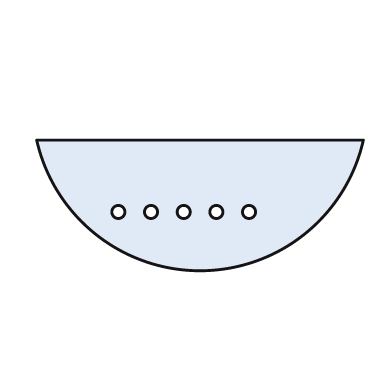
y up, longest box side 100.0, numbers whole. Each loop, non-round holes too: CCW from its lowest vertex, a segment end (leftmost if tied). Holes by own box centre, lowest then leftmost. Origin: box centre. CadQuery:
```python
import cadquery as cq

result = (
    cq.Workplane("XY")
    .moveTo(-50.0, 20.0)
    .threePointArc((0.0, -20.0), (50.0, 20.0))
    .close()
    .moveTo(-25.0, -2.0)
    .circle(2.0)
    .moveTo(-15.0, -2.0)
    .circle(2.0)
    .moveTo(-5.0, -2.0)
    .circle(2.0)
    .moveTo(5.0, -2.0)
    .circle(2.0)
    .moveTo(15.0, -2.0)
    .circle(2.0)
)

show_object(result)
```